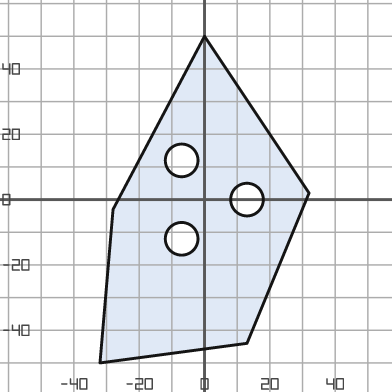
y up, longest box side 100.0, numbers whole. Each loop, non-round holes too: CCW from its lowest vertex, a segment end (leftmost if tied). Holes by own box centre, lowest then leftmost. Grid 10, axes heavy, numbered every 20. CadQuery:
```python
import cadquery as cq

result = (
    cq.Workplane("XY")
    .moveTo(-32.0, -50.0)
    .lineTo(13.0, -44.0)
    .lineTo(32.0, 2.0)
    .lineTo(0.0, 50.0)
    .lineTo(-28.0, -3.0)
    .close()
    .moveTo(-7.0, -12.0)
    .circle(5.0)
    .moveTo(13.0, 0.0)
    .circle(5.0)
    .moveTo(-7.0, 12.0)
    .circle(5.0)
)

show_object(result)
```